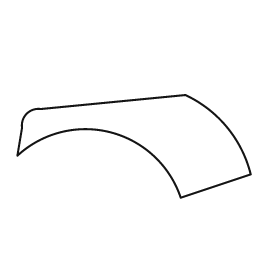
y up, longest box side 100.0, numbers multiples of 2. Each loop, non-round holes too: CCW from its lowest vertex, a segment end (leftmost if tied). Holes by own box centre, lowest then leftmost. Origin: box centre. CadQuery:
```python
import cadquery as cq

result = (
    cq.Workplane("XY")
    .moveTo(20.0, -22.0)
    .lineTo(50.0, -12.0)
    .threePointArc((40.0, 8.0), (22.0, 22.0))
    .lineTo(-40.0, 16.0)
    .threePointArc((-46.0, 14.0), (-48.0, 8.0))
    .lineTo(-50.0, -4.0)
    .threePointArc((-10.0, 6.0), (20.0, -22.0))
    .close()
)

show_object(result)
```